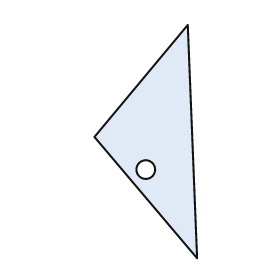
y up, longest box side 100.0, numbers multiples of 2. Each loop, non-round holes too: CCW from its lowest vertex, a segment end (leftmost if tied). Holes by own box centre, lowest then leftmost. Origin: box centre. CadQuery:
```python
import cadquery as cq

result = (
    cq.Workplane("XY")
    .moveTo(22.0, -50.0)
    .lineTo(18.0, 50.0)
    .lineTo(-22.0, 2.0)
    .close()
    .moveTo(0.0, -12.0)
    .circle(4.0)
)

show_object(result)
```